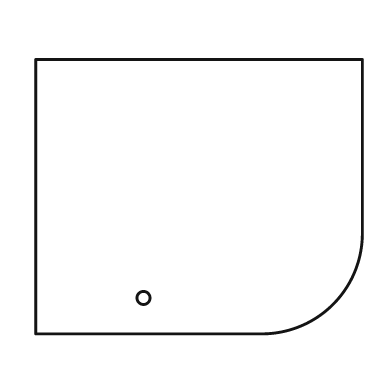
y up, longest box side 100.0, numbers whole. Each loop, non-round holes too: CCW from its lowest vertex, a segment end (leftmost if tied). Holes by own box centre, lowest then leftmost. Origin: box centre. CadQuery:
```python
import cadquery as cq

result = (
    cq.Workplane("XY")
    .moveTo(-50.0, -42.0)
    .lineTo(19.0, -42.0)
    .threePointArc((41.0, -33.0), (50.0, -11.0))
    .lineTo(50.0, 42.0)
    .lineTo(-50.0, 42.0)
    .close()
    .moveTo(-17.0, -31.0)
    .circle(2.0)
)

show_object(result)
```